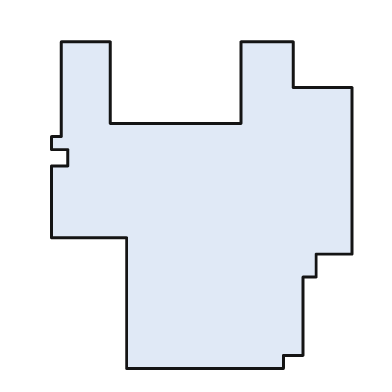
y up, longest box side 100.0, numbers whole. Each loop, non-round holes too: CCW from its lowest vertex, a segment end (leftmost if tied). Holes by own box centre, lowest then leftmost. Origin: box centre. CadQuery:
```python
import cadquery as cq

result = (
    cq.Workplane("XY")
    .moveTo(-23.0, -50.0)
    .lineTo(25.0, -50.0)
    .lineTo(25.0, -46.0)
    .lineTo(31.0, -46.0)
    .lineTo(31.0, -22.0)
    .lineTo(35.0, -22.0)
    .lineTo(35.0, -15.0)
    .lineTo(46.0, -15.0)
    .lineTo(46.0, 36.0)
    .lineTo(28.0, 36.0)
    .lineTo(28.0, 50.0)
    .lineTo(12.0, 50.0)
    .lineTo(12.0, 25.0)
    .lineTo(-28.0, 25.0)
    .lineTo(-28.0, 50.0)
    .lineTo(-43.0, 50.0)
    .lineTo(-43.0, 21.0)
    .lineTo(-46.0, 21.0)
    .lineTo(-46.0, 17.0)
    .lineTo(-41.0, 17.0)
    .lineTo(-41.0, 12.0)
    .lineTo(-46.0, 12.0)
    .lineTo(-46.0, -10.0)
    .lineTo(-23.0, -10.0)
    .close()
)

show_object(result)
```